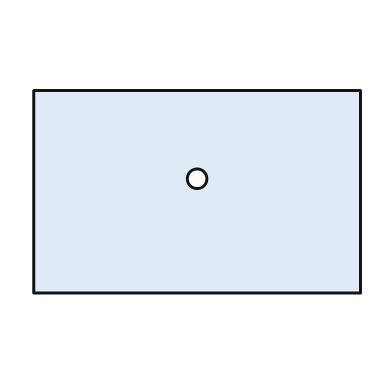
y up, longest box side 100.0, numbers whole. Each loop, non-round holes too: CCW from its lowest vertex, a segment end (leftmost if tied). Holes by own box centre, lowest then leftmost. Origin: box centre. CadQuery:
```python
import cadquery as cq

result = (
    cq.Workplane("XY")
    .moveTo(-50.0, -31.0)
    .lineTo(50.0, -31.0)
    .lineTo(50.0, 31.0)
    .lineTo(-50.0, 31.0)
    .close()
    .moveTo(0.0, 4.0)
    .circle(3.0)
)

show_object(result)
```